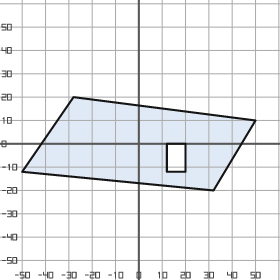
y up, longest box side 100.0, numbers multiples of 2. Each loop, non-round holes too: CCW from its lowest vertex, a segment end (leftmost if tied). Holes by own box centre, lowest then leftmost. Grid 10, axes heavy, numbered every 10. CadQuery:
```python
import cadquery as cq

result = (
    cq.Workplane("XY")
    .moveTo(32.0, -20.0)
    .lineTo(50.0, 10.0)
    .lineTo(-28.0, 20.0)
    .lineTo(-50.0, -12.0)
    .close()
    .moveTo(12.0, -12.0)
    .lineTo(20.0, -12.0)
    .lineTo(20.0, 0.0)
    .lineTo(12.0, 0.0)
    .close()
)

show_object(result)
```